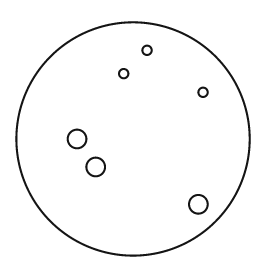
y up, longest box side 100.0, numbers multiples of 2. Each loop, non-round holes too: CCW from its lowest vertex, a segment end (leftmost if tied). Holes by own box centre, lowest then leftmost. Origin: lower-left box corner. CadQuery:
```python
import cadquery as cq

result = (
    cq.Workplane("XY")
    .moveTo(50.0, 50.0)
    .circle(50.0)
    .moveTo(78.0, 22.0)
    .circle(4.0)
    .moveTo(34.0, 38.0)
    .circle(4.0)
    .moveTo(26.0, 50.0)
    .circle(4.0)
    .moveTo(80.0, 70.0)
    .circle(2.0)
    .moveTo(46.0, 78.0)
    .circle(2.0)
    .moveTo(56.0, 88.0)
    .circle(2.0)
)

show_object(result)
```